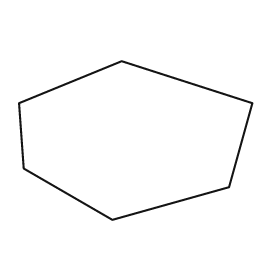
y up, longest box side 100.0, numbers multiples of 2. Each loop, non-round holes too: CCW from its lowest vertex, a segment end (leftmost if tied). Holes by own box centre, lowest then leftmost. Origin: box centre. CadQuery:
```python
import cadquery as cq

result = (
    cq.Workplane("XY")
    .moveTo(-10.0, -34.0)
    .lineTo(40.0, -20.0)
    .lineTo(50.0, 16.0)
    .lineTo(-6.0, 34.0)
    .lineTo(-50.0, 16.0)
    .lineTo(-48.0, -12.0)
    .close()
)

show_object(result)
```